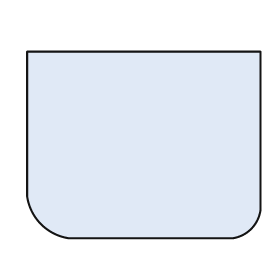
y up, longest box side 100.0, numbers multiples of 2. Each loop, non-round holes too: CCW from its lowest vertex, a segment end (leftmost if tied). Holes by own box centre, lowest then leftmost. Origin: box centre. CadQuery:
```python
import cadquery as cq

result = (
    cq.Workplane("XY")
    .moveTo(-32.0, -40.0)
    .lineTo(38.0, -40.0)
    .threePointArc((46.0, -36.0), (50.0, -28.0))
    .lineTo(50.0, 40.0)
    .lineTo(-50.0, 40.0)
    .lineTo(-50.0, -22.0)
    .threePointArc((-44.0, -34.0), (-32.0, -40.0))
    .close()
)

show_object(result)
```